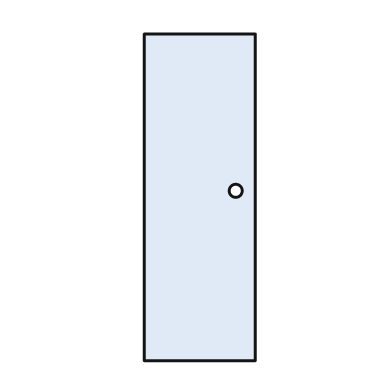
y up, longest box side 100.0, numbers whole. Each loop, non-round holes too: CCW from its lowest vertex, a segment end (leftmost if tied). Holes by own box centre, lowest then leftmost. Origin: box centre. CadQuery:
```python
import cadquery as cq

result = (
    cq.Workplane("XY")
    .moveTo(-17.0, -50.0)
    .lineTo(17.0, -50.0)
    .lineTo(17.0, 50.0)
    .lineTo(-17.0, 50.0)
    .close()
    .moveTo(11.0, 2.0)
    .circle(2.0)
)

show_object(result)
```